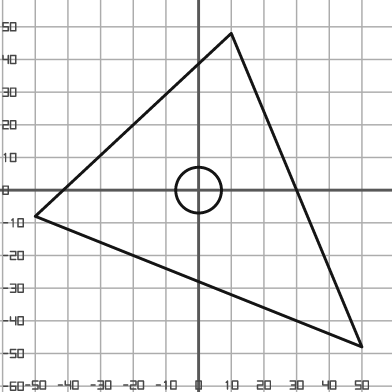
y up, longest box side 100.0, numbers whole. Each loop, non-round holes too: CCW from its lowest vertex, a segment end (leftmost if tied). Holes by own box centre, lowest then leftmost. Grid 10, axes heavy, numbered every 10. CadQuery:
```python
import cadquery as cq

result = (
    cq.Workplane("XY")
    .moveTo(50.0, -48.0)
    .lineTo(10.0, 48.0)
    .lineTo(-50.0, -8.0)
    .close()
    .moveTo(0.0, 0.0)
    .circle(7.0)
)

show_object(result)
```